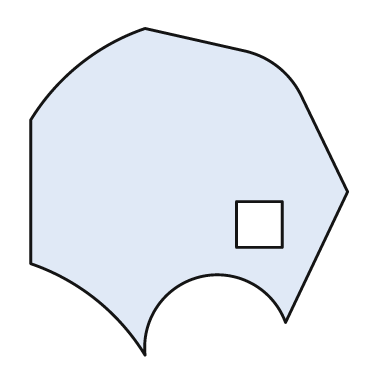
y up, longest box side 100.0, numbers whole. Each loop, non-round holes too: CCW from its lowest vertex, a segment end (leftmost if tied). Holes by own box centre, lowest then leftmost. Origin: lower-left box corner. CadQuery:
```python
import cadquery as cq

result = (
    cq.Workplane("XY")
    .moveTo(35.0, 0.0)
    .threePointArc((52.0, 24.0), (78.0, 10.0))
    .lineTo(97.0, 50.0)
    .lineTo(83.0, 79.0)
    .threePointArc((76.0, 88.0), (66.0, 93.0))
    .lineTo(35.0, 100.0)
    .threePointArc((15.0, 89.0), (0.0, 72.0))
    .lineTo(0.0, 28.0)
    .threePointArc((20.0, 17.0), (35.0, 0.0))
    .close()
    .moveTo(63.0, 33.0)
    .lineTo(77.0, 33.0)
    .lineTo(77.0, 47.0)
    .lineTo(63.0, 47.0)
    .close()
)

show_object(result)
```